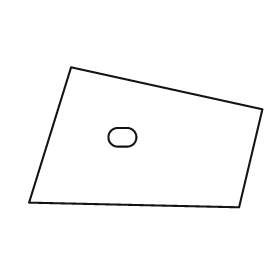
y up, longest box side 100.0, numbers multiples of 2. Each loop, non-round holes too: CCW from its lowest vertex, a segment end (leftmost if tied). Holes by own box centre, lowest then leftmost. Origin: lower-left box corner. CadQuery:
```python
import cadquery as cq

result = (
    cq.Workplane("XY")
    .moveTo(90.0, 0.0)
    .lineTo(100.0, 42.0)
    .lineTo(18.0, 60.0)
    .lineTo(0.0, 2.0)
    .close()
    .moveTo(38.0, 26.0)
    .lineTo(42.0, 26.0)
    .threePointArc((46.0, 30.0), (42.0, 34.0))
    .lineTo(38.0, 34.0)
    .threePointArc((34.0, 30.0), (38.0, 26.0))
    .close()
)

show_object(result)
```